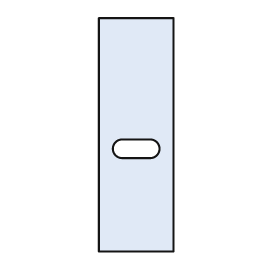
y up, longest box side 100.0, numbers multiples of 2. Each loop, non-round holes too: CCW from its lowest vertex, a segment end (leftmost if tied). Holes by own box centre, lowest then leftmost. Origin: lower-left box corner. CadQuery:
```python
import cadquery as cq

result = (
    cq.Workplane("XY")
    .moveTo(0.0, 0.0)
    .lineTo(32.0, 0.0)
    .lineTo(32.0, 100.0)
    .lineTo(0.0, 100.0)
    .close()
    .moveTo(10.0, 40.0)
    .lineTo(22.0, 40.0)
    .threePointArc((26.0, 44.0), (22.0, 48.0))
    .lineTo(10.0, 48.0)
    .threePointArc((6.0, 44.0), (10.0, 40.0))
    .close()
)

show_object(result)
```